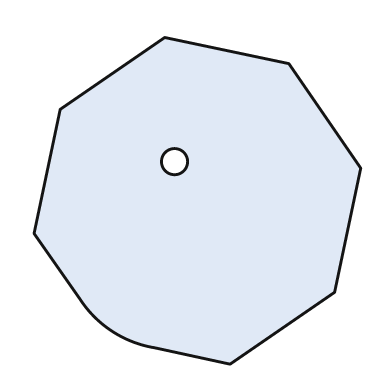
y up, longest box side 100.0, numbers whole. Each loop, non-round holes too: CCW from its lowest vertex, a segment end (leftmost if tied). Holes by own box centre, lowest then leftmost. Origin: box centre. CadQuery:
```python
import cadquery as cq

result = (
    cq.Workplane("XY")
    .moveTo(10.0, -50.0)
    .lineTo(42.0, -28.0)
    .lineTo(50.0, 10.0)
    .lineTo(28.0, 42.0)
    .lineTo(-10.0, 50.0)
    .lineTo(-42.0, 28.0)
    .lineTo(-50.0, -10.0)
    .lineTo(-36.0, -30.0)
    .threePointArc((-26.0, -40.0), (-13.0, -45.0))
    .close()
    .moveTo(-7.0, 12.0)
    .circle(4.0)
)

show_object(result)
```